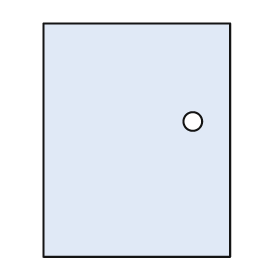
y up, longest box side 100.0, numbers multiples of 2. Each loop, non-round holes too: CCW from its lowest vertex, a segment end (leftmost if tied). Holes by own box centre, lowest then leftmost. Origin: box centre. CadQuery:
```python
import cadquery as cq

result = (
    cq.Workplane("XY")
    .moveTo(-40.0, -50.0)
    .lineTo(40.0, -50.0)
    .lineTo(40.0, 50.0)
    .lineTo(-40.0, 50.0)
    .close()
    .moveTo(24.0, 8.0)
    .circle(4.0)
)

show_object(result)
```